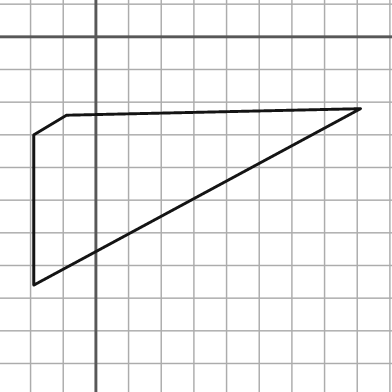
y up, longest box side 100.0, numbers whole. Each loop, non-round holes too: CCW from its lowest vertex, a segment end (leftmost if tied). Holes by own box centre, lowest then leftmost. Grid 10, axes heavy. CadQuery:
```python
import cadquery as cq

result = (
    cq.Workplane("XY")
    .moveTo(-19.0, -76.0)
    .lineTo(81.0, -22.0)
    .lineTo(-9.0, -24.0)
    .lineTo(-19.0, -30.0)
    .close()
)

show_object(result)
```